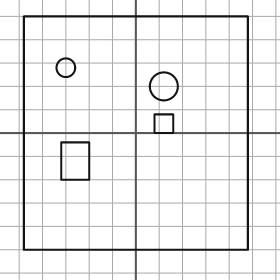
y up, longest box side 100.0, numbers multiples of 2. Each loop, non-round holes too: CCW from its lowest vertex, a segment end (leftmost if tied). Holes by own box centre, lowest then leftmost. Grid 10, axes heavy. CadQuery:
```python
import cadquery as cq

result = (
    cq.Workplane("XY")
    .moveTo(-48.0, -50.0)
    .lineTo(48.0, -50.0)
    .lineTo(48.0, 50.0)
    .lineTo(-48.0, 50.0)
    .close()
    .moveTo(-32.0, -20.0)
    .lineTo(-20.0, -20.0)
    .lineTo(-20.0, -4.0)
    .lineTo(-32.0, -4.0)
    .close()
    .moveTo(8.0, 0.0)
    .lineTo(16.0, 0.0)
    .lineTo(16.0, 8.0)
    .lineTo(8.0, 8.0)
    .close()
    .moveTo(12.0, 20.0)
    .circle(6.0)
    .moveTo(-30.0, 28.0)
    .circle(4.0)
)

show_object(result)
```